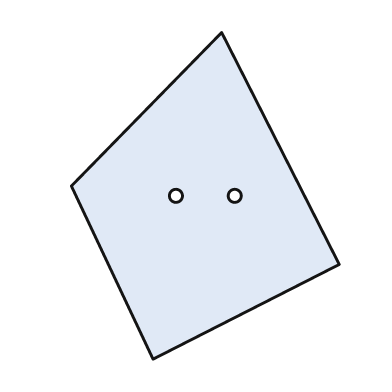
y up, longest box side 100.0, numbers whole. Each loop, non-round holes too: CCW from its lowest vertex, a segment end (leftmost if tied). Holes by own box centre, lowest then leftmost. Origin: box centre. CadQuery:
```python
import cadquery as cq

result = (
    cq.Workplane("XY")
    .moveTo(-16.0, -50.0)
    .lineTo(41.0, -21.0)
    .lineTo(5.0, 50.0)
    .lineTo(-41.0, 3.0)
    .close()
    .moveTo(-9.0, 0.0)
    .circle(2.0)
    .moveTo(9.0, 0.0)
    .circle(2.0)
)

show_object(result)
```